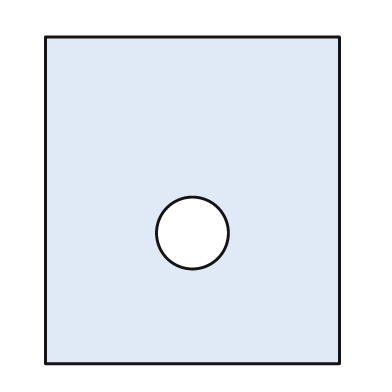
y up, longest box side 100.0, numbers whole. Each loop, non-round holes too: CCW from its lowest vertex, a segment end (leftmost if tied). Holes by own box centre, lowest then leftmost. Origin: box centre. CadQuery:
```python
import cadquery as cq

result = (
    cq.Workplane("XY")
    .moveTo(-45.0, -50.0)
    .lineTo(45.0, -50.0)
    .lineTo(45.0, 50.0)
    .lineTo(-45.0, 50.0)
    .close()
    .moveTo(0.0, -10.0)
    .circle(11.0)
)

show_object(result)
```